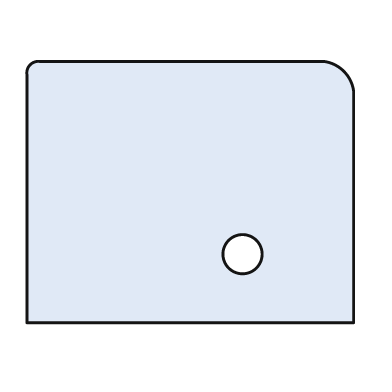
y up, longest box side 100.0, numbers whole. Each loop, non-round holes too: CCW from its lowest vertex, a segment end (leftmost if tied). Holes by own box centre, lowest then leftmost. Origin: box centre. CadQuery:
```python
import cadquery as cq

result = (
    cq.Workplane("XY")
    .moveTo(-50.0, -40.0)
    .lineTo(50.0, -40.0)
    .lineTo(50.0, 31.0)
    .threePointArc((47.0, 37.0), (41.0, 40.0))
    .lineTo(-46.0, 40.0)
    .threePointArc((-49.0, 39.0), (-50.0, 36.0))
    .close()
    .moveTo(16.0, -19.0)
    .circle(6.0)
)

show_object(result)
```